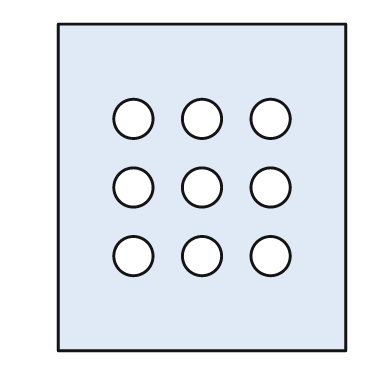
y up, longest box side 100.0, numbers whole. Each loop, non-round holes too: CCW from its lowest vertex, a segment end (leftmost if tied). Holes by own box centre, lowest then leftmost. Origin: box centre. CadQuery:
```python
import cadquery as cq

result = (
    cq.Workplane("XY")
    .moveTo(-44.0, -50.0)
    .lineTo(44.0, -50.0)
    .lineTo(44.0, 50.0)
    .lineTo(-44.0, 50.0)
    .close()
    .moveTo(-21.0, -21.0)
    .circle(6.0)
    .moveTo(0.0, -21.0)
    .circle(6.0)
    .moveTo(21.0, -21.0)
    .circle(6.0)
    .moveTo(-21.0, 0.0)
    .circle(6.0)
    .moveTo(0.0, 0.0)
    .circle(6.0)
    .moveTo(21.0, 0.0)
    .circle(6.0)
    .moveTo(-21.0, 21.0)
    .circle(6.0)
    .moveTo(0.0, 21.0)
    .circle(6.0)
    .moveTo(21.0, 21.0)
    .circle(6.0)
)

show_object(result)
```